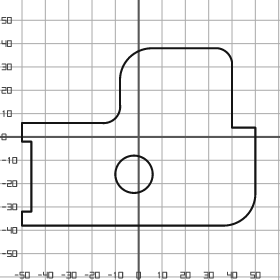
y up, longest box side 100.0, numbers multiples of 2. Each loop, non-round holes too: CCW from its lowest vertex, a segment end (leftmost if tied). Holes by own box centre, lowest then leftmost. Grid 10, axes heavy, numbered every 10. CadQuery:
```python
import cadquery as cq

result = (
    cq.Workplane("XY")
    .moveTo(-50.0, -38.0)
    .lineTo(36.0, -38.0)
    .threePointArc((46.0, -34.0), (50.0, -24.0))
    .lineTo(50.0, 4.0)
    .lineTo(40.0, 4.0)
    .lineTo(40.0, 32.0)
    .threePointArc((38.0, 36.0), (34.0, 38.0))
    .lineTo(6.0, 38.0)
    .threePointArc((-4.0, 34.0), (-8.0, 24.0))
    .lineTo(-8.0, 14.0)
    .threePointArc((-10.0, 8.0), (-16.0, 6.0))
    .lineTo(-50.0, 6.0)
    .lineTo(-50.0, -2.0)
    .lineTo(-46.0, -2.0)
    .lineTo(-46.0, -32.0)
    .lineTo(-50.0, -32.0)
    .close()
    .moveTo(-2.0, -16.0)
    .circle(8.0)
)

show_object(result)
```